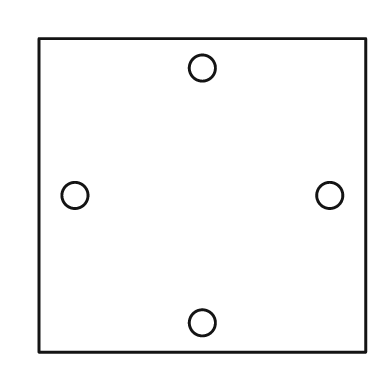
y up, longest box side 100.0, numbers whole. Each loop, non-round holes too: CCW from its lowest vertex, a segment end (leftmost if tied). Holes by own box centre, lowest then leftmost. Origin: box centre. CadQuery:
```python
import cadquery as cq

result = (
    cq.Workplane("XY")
    .moveTo(-50.0, -48.0)
    .lineTo(50.0, -48.0)
    .lineTo(50.0, 48.0)
    .lineTo(-50.0, 48.0)
    .close()
    .moveTo(0.0, -39.0)
    .circle(4.0)
    .moveTo(-39.0, 0.0)
    .circle(4.0)
    .moveTo(39.0, 0.0)
    .circle(4.0)
    .moveTo(0.0, 39.0)
    .circle(4.0)
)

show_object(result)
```